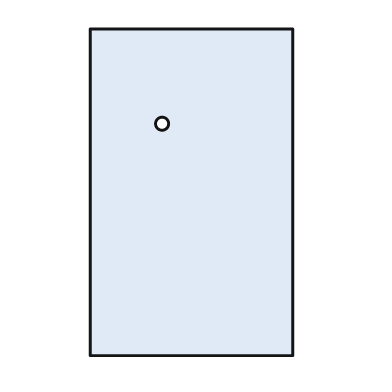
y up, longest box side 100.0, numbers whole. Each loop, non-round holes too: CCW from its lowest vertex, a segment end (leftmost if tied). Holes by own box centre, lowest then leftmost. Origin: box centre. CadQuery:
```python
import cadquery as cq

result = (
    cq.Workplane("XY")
    .moveTo(-31.0, -50.0)
    .lineTo(31.0, -50.0)
    .lineTo(31.0, 50.0)
    .lineTo(-31.0, 50.0)
    .close()
    .moveTo(-9.0, 21.0)
    .circle(2.0)
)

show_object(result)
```